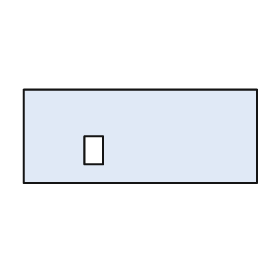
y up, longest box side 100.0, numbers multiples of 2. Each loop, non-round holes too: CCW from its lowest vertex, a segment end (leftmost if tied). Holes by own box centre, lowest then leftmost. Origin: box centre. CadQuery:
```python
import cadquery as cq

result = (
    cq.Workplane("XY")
    .moveTo(-50.0, -20.0)
    .lineTo(50.0, -20.0)
    .lineTo(50.0, 20.0)
    .lineTo(-50.0, 20.0)
    .close()
    .moveTo(-24.0, -12.0)
    .lineTo(-16.0, -12.0)
    .lineTo(-16.0, 0.0)
    .lineTo(-24.0, 0.0)
    .close()
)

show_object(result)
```